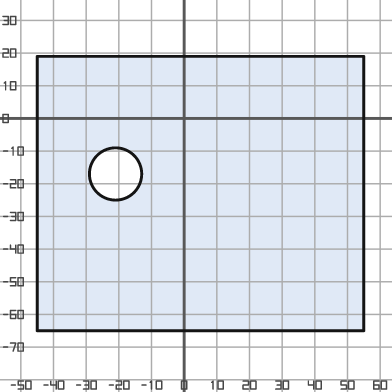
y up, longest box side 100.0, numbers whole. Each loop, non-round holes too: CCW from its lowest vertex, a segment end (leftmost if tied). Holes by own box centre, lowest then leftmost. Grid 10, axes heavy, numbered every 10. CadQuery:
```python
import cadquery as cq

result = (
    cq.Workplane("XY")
    .moveTo(-45.0, -65.0)
    .lineTo(55.0, -65.0)
    .lineTo(55.0, 19.0)
    .lineTo(-45.0, 19.0)
    .close()
    .moveTo(-21.0, -17.0)
    .circle(8.0)
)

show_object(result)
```